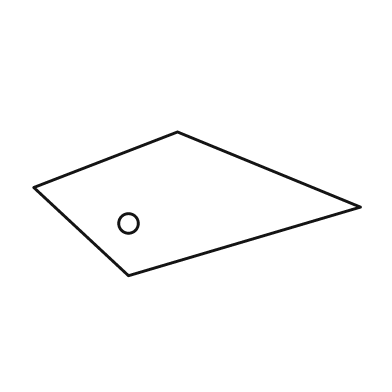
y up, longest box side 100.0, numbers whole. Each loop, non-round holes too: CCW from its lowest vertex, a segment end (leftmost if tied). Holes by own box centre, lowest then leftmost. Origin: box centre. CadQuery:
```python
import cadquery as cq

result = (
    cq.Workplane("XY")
    .moveTo(-21.0, -22.0)
    .lineTo(50.0, -1.0)
    .lineTo(-6.0, 22.0)
    .lineTo(-50.0, 5.0)
    .close()
    .moveTo(-21.0, -6.0)
    .circle(3.0)
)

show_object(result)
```